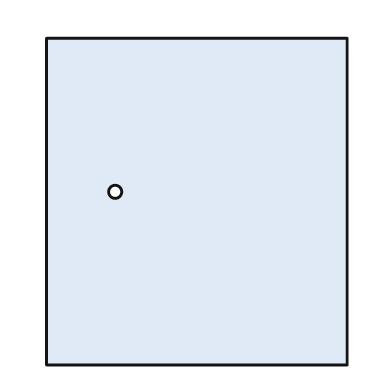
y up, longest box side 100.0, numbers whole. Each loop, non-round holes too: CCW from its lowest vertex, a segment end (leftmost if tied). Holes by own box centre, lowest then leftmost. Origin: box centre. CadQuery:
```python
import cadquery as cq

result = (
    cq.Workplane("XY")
    .moveTo(-46.0, -50.0)
    .lineTo(46.0, -50.0)
    .lineTo(46.0, 50.0)
    .lineTo(-46.0, 50.0)
    .close()
    .moveTo(-25.0, 3.0)
    .circle(2.0)
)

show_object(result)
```